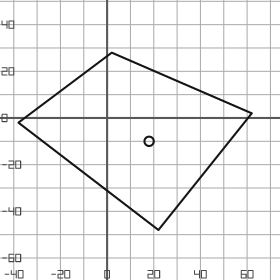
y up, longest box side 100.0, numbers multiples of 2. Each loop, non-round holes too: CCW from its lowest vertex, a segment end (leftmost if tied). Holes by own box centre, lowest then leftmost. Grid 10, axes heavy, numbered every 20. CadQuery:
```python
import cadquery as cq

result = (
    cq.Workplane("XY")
    .moveTo(22.0, -48.0)
    .lineTo(62.0, 2.0)
    .lineTo(2.0, 28.0)
    .lineTo(-38.0, -2.0)
    .close()
    .moveTo(18.0, -10.0)
    .circle(2.0)
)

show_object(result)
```